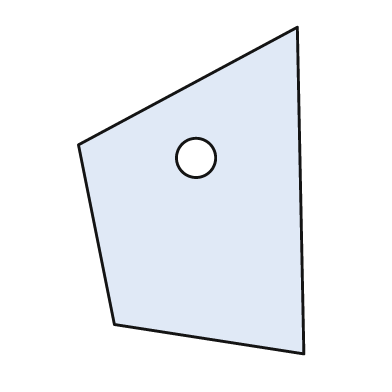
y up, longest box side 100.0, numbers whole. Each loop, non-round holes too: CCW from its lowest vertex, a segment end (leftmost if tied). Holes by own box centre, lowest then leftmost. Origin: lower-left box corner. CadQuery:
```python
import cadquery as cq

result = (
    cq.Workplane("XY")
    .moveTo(69.0, 0.0)
    .lineTo(67.0, 100.0)
    .lineTo(0.0, 64.0)
    .lineTo(11.0, 9.0)
    .close()
    .moveTo(36.0, 60.0)
    .circle(6.0)
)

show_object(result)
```